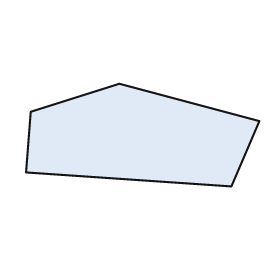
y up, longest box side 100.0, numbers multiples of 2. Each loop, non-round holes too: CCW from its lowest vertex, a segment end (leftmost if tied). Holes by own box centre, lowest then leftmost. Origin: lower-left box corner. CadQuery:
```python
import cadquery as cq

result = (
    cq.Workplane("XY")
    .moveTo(88.0, 0.0)
    .lineTo(100.0, 28.0)
    .lineTo(40.0, 44.0)
    .lineTo(2.0, 32.0)
    .lineTo(0.0, 6.0)
    .close()
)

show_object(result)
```